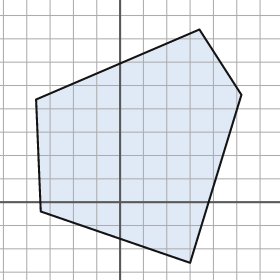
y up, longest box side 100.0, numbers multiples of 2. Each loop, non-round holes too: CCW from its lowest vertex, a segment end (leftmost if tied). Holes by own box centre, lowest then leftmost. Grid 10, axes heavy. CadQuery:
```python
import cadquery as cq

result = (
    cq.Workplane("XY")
    .moveTo(30.0, -26.0)
    .lineTo(52.0, 46.0)
    .lineTo(34.0, 74.0)
    .lineTo(-36.0, 44.0)
    .lineTo(-34.0, -4.0)
    .close()
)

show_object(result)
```